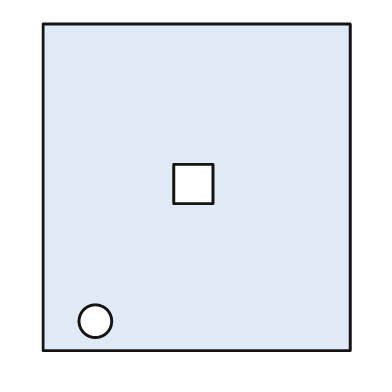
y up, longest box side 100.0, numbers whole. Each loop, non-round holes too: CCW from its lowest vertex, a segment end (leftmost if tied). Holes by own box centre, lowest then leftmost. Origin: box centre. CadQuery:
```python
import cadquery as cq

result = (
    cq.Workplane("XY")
    .moveTo(-47.0, -50.0)
    .lineTo(47.0, -50.0)
    .lineTo(47.0, 50.0)
    .lineTo(-47.0, 50.0)
    .close()
    .moveTo(-31.0, -41.0)
    .circle(5.0)
    .moveTo(-7.0, -5.0)
    .lineTo(5.0, -5.0)
    .lineTo(5.0, 7.0)
    .lineTo(-7.0, 7.0)
    .close()
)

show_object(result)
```